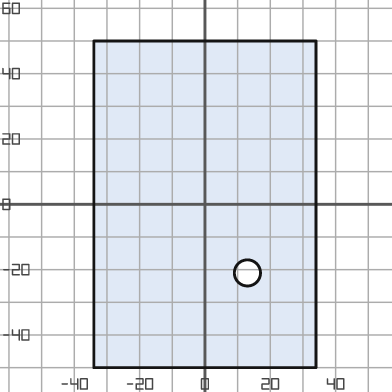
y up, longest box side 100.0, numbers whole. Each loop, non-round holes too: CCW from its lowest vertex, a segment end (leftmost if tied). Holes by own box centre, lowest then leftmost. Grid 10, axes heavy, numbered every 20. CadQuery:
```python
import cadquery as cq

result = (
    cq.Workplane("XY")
    .moveTo(-34.0, -50.0)
    .lineTo(34.0, -50.0)
    .lineTo(34.0, 50.0)
    .lineTo(-34.0, 50.0)
    .close()
    .moveTo(13.0, -21.0)
    .circle(4.0)
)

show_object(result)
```